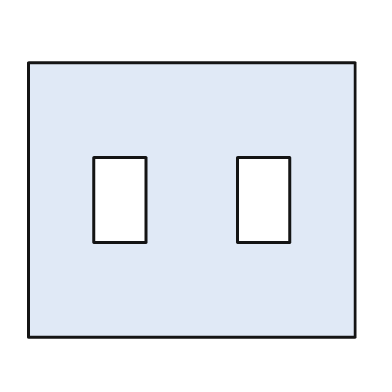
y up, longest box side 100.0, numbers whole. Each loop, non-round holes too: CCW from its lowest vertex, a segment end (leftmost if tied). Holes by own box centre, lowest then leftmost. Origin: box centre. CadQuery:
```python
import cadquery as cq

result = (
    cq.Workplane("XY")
    .moveTo(-50.0, -42.0)
    .lineTo(50.0, -42.0)
    .lineTo(50.0, 42.0)
    .lineTo(-50.0, 42.0)
    .close()
    .moveTo(-30.0, -13.0)
    .lineTo(-14.0, -13.0)
    .lineTo(-14.0, 13.0)
    .lineTo(-30.0, 13.0)
    .close()
    .moveTo(14.0, -13.0)
    .lineTo(30.0, -13.0)
    .lineTo(30.0, 13.0)
    .lineTo(14.0, 13.0)
    .close()
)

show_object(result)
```